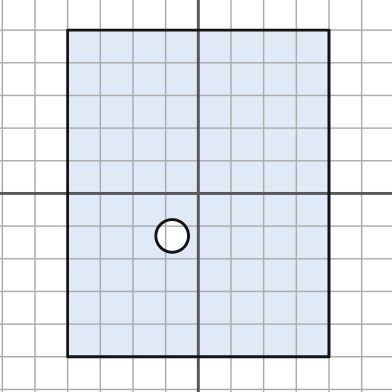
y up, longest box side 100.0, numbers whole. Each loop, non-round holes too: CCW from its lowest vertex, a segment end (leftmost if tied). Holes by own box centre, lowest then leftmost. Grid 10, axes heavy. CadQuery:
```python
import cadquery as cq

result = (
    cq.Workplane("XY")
    .moveTo(-40.0, -50.0)
    .lineTo(40.0, -50.0)
    .lineTo(40.0, 50.0)
    .lineTo(-40.0, 50.0)
    .close()
    .moveTo(-8.0, -13.0)
    .circle(5.0)
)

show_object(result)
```